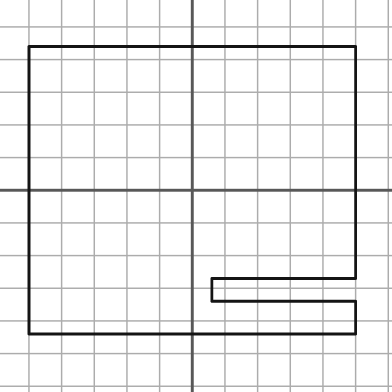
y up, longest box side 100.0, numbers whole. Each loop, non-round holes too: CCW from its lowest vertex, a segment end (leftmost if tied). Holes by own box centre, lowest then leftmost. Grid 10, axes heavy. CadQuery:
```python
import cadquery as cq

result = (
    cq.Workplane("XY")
    .moveTo(-50.0, -44.0)
    .lineTo(50.0, -44.0)
    .lineTo(50.0, -34.0)
    .lineTo(6.0, -34.0)
    .lineTo(6.0, -27.0)
    .lineTo(50.0, -27.0)
    .lineTo(50.0, 44.0)
    .lineTo(-50.0, 44.0)
    .close()
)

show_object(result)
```